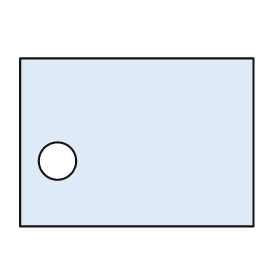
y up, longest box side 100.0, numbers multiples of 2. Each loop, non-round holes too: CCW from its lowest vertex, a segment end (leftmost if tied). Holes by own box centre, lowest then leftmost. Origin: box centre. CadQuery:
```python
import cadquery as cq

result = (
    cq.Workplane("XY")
    .moveTo(-50.0, -36.0)
    .lineTo(50.0, -36.0)
    .lineTo(50.0, 36.0)
    .lineTo(-50.0, 36.0)
    .close()
    .moveTo(-34.0, -8.0)
    .circle(8.0)
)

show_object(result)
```